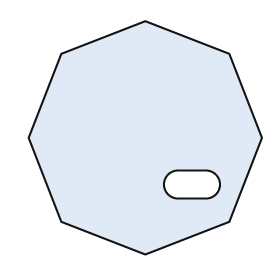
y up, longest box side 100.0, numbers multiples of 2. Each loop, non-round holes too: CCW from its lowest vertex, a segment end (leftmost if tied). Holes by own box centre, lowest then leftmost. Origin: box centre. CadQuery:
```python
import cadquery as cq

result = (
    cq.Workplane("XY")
    .moveTo(0.0, -50.0)
    .lineTo(36.0, -36.0)
    .lineTo(50.0, 0.0)
    .lineTo(36.0, 36.0)
    .lineTo(0.0, 50.0)
    .lineTo(-36.0, 36.0)
    .lineTo(-50.0, 0.0)
    .lineTo(-36.0, -36.0)
    .close()
    .moveTo(14.0, -26.0)
    .lineTo(26.0, -26.0)
    .threePointArc((32.0, -20.0), (26.0, -14.0))
    .lineTo(14.0, -14.0)
    .threePointArc((8.0, -20.0), (14.0, -26.0))
    .close()
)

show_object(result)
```